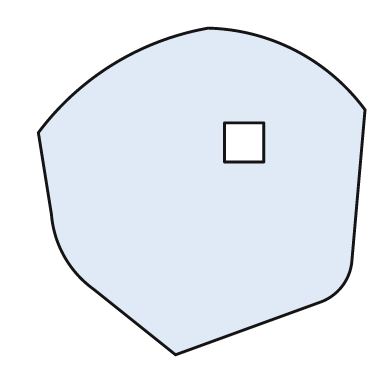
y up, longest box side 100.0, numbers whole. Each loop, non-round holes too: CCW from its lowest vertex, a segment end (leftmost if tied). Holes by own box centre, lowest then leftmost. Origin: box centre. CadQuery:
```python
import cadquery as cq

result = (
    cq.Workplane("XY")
    .moveTo(-8.0, -50.0)
    .lineTo(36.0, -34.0)
    .threePointArc((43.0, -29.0), (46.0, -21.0))
    .lineTo(50.0, 25.0)
    .threePointArc((29.0, 43.0), (2.0, 50.0))
    .threePointArc((-27.0, 39.0), (-50.0, 18.0))
    .lineTo(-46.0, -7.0)
    .threePointArc((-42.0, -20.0), (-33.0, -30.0))
    .close()
    .moveTo(7.0, 9.0)
    .lineTo(19.0, 9.0)
    .lineTo(19.0, 21.0)
    .lineTo(7.0, 21.0)
    .close()
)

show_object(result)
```